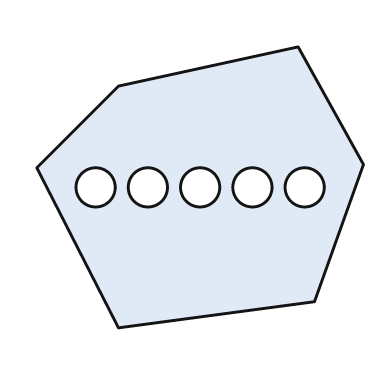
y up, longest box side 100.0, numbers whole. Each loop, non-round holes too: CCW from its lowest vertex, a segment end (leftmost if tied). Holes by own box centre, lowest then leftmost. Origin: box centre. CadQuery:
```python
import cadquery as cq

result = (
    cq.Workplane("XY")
    .moveTo(-25.0, -43.0)
    .lineTo(35.0, -35.0)
    .lineTo(50.0, 7.0)
    .lineTo(30.0, 43.0)
    .lineTo(-25.0, 31.0)
    .lineTo(-50.0, 6.0)
    .close()
    .moveTo(-32.0, 0.0)
    .circle(6.0)
    .moveTo(-16.0, 0.0)
    .circle(6.0)
    .moveTo(0.0, 0.0)
    .circle(6.0)
    .moveTo(16.0, 0.0)
    .circle(6.0)
    .moveTo(32.0, 0.0)
    .circle(6.0)
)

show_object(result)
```